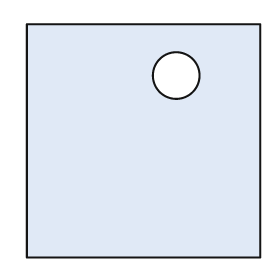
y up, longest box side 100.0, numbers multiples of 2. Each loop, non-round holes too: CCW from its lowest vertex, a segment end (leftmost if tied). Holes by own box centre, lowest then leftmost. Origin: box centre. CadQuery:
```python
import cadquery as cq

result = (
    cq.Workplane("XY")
    .moveTo(-50.0, -50.0)
    .lineTo(50.0, -50.0)
    .lineTo(50.0, 50.0)
    .lineTo(-50.0, 50.0)
    .close()
    .moveTo(14.0, 28.0)
    .circle(10.0)
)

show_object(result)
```